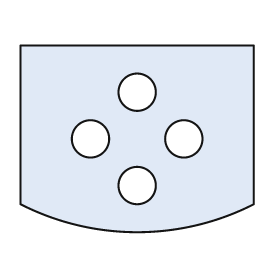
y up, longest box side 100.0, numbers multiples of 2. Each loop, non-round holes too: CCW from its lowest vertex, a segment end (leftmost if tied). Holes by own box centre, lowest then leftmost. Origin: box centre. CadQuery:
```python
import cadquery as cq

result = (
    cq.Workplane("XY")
    .moveTo(-50.0, -28.0)
    .threePointArc((0.0, -40.0), (50.0, -28.0))
    .lineTo(50.0, 40.0)
    .lineTo(-50.0, 40.0)
    .close()
    .moveTo(0.0, -20.0)
    .circle(8.0)
    .moveTo(-20.0, 0.0)
    .circle(8.0)
    .moveTo(20.0, 0.0)
    .circle(8.0)
    .moveTo(0.0, 20.0)
    .circle(8.0)
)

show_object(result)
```